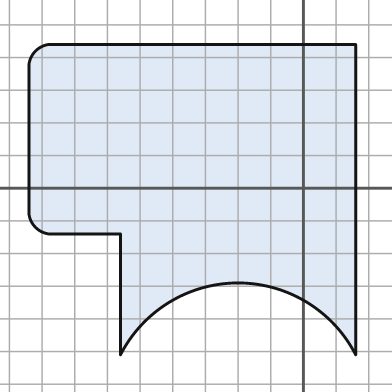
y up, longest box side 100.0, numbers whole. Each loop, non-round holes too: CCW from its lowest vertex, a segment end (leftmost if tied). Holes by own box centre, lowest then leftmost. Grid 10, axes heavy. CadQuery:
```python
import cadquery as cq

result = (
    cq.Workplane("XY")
    .moveTo(-56.0, -51.0)
    .threePointArc((-20.0, -29.0), (16.0, -51.0))
    .lineTo(16.0, 44.0)
    .lineTo(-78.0, 44.0)
    .threePointArc((-82.0, 42.0), (-84.0, 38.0))
    .lineTo(-84.0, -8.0)
    .threePointArc((-82.0, -12.0), (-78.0, -14.0))
    .lineTo(-56.0, -14.0)
    .close()
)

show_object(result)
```